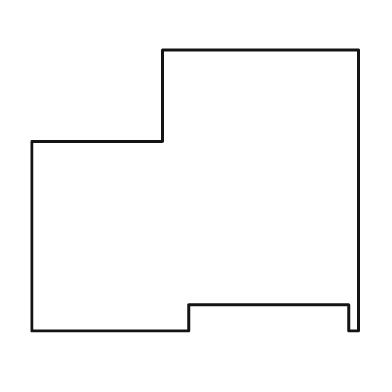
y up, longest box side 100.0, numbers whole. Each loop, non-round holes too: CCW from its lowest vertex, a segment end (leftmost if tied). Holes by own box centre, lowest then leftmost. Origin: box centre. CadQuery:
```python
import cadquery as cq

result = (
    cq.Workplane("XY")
    .moveTo(-50.0, -43.0)
    .lineTo(-2.0, -43.0)
    .lineTo(-2.0, -35.0)
    .lineTo(47.0, -35.0)
    .lineTo(47.0, -43.0)
    .lineTo(50.0, -43.0)
    .lineTo(50.0, 43.0)
    .lineTo(-10.0, 43.0)
    .lineTo(-10.0, 15.0)
    .lineTo(-50.0, 15.0)
    .close()
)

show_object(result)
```